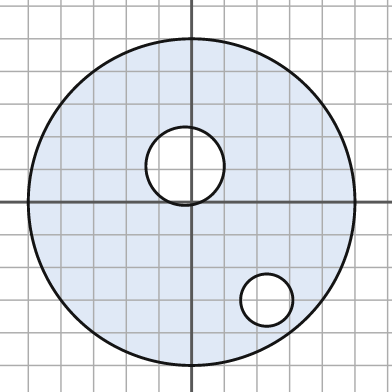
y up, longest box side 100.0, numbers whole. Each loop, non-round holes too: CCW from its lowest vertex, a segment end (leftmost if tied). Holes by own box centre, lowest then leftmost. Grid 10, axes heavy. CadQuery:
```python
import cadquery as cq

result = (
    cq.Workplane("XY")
    .moveTo(0.0, 0.0)
    .circle(50.0)
    .moveTo(23.0, -30.0)
    .circle(8.0)
    .moveTo(-2.0, 11.0)
    .circle(12.0)
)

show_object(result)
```